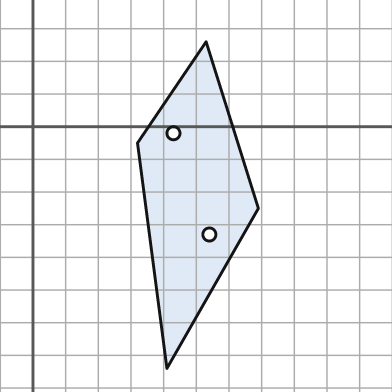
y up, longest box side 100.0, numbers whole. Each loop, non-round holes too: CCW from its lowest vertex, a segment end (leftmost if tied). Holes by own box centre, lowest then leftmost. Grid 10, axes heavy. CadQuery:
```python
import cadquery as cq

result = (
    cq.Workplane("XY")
    .moveTo(41.0, -74.0)
    .lineTo(69.0, -25.0)
    .lineTo(53.0, 26.0)
    .lineTo(32.0, -5.0)
    .close()
    .moveTo(54.0, -33.0)
    .circle(2.0)
    .moveTo(43.0, -2.0)
    .circle(2.0)
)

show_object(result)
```